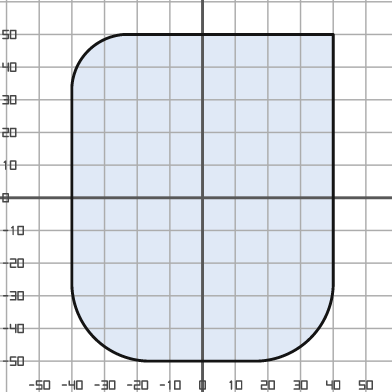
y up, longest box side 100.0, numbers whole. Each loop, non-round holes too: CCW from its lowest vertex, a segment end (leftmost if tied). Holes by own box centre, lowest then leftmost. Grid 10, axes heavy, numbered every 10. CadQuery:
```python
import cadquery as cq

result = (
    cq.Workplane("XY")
    .moveTo(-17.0, -50.0)
    .lineTo(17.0, -50.0)
    .threePointArc((33.0, -43.0), (40.0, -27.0))
    .lineTo(40.0, 50.0)
    .lineTo(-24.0, 50.0)
    .threePointArc((-35.0, 45.0), (-40.0, 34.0))
    .lineTo(-40.0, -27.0)
    .threePointArc((-33.0, -43.0), (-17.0, -50.0))
    .close()
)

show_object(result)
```